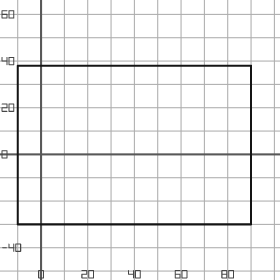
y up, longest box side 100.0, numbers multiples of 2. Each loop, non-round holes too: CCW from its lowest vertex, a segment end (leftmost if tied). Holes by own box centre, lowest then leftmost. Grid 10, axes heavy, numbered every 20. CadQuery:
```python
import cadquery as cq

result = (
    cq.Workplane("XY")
    .moveTo(-10.0, -30.0)
    .lineTo(90.0, -30.0)
    .lineTo(90.0, 38.0)
    .lineTo(-10.0, 38.0)
    .close()
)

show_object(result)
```